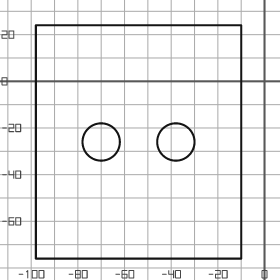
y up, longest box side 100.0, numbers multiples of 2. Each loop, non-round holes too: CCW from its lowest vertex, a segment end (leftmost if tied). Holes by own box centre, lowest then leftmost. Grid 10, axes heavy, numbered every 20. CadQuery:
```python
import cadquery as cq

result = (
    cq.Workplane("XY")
    .moveTo(-98.0, -76.0)
    .lineTo(-10.0, -76.0)
    .lineTo(-10.0, 24.0)
    .lineTo(-98.0, 24.0)
    .close()
    .moveTo(-70.0, -26.0)
    .circle(8.0)
    .moveTo(-38.0, -26.0)
    .circle(8.0)
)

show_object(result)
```